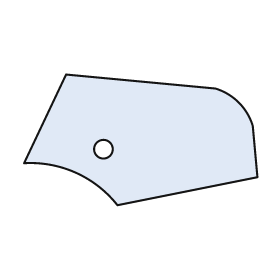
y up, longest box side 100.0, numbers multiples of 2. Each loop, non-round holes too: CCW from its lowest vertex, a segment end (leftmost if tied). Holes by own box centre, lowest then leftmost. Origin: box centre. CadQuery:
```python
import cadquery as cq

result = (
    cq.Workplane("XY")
    .moveTo(-10.0, -28.0)
    .lineTo(50.0, -16.0)
    .lineTo(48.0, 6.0)
    .threePointArc((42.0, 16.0), (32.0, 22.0))
    .lineTo(-32.0, 28.0)
    .lineTo(-50.0, -10.0)
    .threePointArc((-28.0, -14.0), (-10.0, -28.0))
    .close()
    .moveTo(-16.0, -4.0)
    .circle(4.0)
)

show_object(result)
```